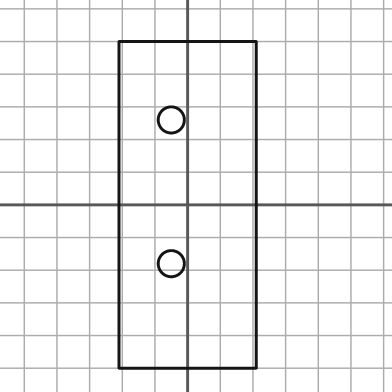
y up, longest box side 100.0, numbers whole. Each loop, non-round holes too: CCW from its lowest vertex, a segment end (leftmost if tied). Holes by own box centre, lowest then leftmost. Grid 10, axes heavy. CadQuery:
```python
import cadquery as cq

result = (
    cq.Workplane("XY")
    .moveTo(-21.0, -50.0)
    .lineTo(21.0, -50.0)
    .lineTo(21.0, 50.0)
    .lineTo(-21.0, 50.0)
    .close()
    .moveTo(-5.0, -18.0)
    .circle(4.0)
    .moveTo(-5.0, 26.0)
    .circle(4.0)
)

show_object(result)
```